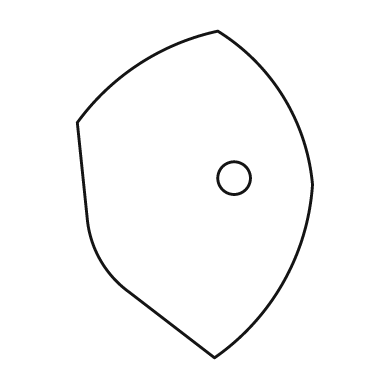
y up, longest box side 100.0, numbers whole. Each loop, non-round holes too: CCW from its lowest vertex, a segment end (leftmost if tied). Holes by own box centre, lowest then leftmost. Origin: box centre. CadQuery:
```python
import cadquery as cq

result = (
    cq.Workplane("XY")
    .moveTo(6.0, -50.0)
    .threePointArc((27.0, -27.0), (36.0, 3.0))
    .threePointArc((27.0, 30.0), (7.0, 50.0))
    .threePointArc((-17.0, 40.0), (-36.0, 22.0))
    .lineTo(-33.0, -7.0)
    .threePointArc((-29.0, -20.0), (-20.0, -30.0))
    .close()
    .moveTo(12.0, 5.0)
    .circle(5.0)
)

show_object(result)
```